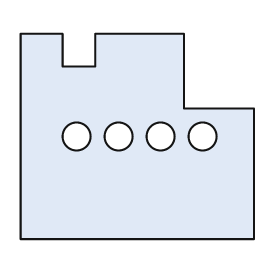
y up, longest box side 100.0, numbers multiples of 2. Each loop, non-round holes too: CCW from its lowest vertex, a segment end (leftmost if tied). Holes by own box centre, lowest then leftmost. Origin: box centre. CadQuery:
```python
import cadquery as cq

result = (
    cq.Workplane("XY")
    .moveTo(-50.0, -44.0)
    .lineTo(50.0, -44.0)
    .lineTo(50.0, 12.0)
    .lineTo(20.0, 12.0)
    .lineTo(20.0, 44.0)
    .lineTo(-18.0, 44.0)
    .lineTo(-18.0, 30.0)
    .lineTo(-32.0, 30.0)
    .lineTo(-32.0, 44.0)
    .lineTo(-50.0, 44.0)
    .close()
    .moveTo(-26.0, 0.0)
    .circle(6.0)
    .moveTo(-8.0, 0.0)
    .circle(6.0)
    .moveTo(10.0, 0.0)
    .circle(6.0)
    .moveTo(28.0, 0.0)
    .circle(6.0)
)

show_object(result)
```